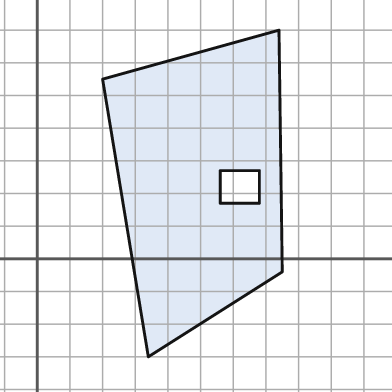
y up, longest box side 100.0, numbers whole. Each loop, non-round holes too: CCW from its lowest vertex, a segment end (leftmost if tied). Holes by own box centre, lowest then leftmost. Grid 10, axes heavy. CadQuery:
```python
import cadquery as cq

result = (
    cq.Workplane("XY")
    .moveTo(34.0, -30.0)
    .lineTo(75.0, -4.0)
    .lineTo(74.0, 70.0)
    .lineTo(20.0, 55.0)
    .close()
    .moveTo(56.0, 17.0)
    .lineTo(68.0, 17.0)
    .lineTo(68.0, 27.0)
    .lineTo(56.0, 27.0)
    .close()
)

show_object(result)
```